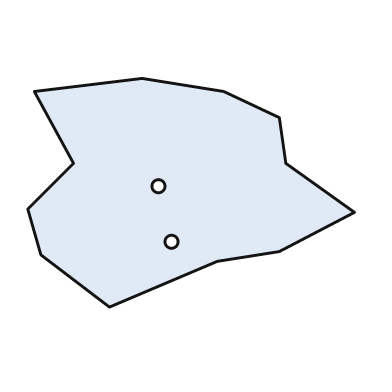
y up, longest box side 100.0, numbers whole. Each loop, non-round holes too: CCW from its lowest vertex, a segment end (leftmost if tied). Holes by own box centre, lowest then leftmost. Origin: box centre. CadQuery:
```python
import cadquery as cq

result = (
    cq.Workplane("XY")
    .moveTo(-25.0, -35.0)
    .lineTo(8.0, -21.0)
    .lineTo(27.0, -18.0)
    .lineTo(50.0, -6.0)
    .lineTo(29.0, 9.0)
    .lineTo(27.0, 23.0)
    .lineTo(10.0, 31.0)
    .lineTo(-15.0, 35.0)
    .lineTo(-48.0, 31.0)
    .lineTo(-36.0, 9.0)
    .lineTo(-50.0, -5.0)
    .lineTo(-46.0, -19.0)
    .close()
    .moveTo(-6.0, -15.0)
    .circle(2.0)
    .moveTo(-10.0, 2.0)
    .circle(2.0)
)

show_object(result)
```